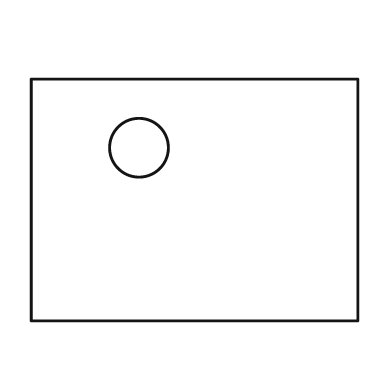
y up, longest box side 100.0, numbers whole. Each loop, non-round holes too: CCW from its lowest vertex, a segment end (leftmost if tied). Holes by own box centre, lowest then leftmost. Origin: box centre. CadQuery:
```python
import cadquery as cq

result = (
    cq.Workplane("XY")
    .moveTo(-50.0, -37.0)
    .lineTo(50.0, -37.0)
    .lineTo(50.0, 37.0)
    .lineTo(-50.0, 37.0)
    .close()
    .moveTo(-17.0, 16.0)
    .circle(9.0)
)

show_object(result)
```